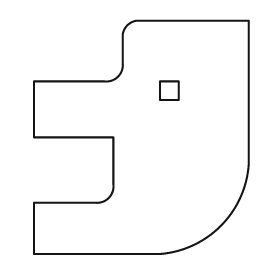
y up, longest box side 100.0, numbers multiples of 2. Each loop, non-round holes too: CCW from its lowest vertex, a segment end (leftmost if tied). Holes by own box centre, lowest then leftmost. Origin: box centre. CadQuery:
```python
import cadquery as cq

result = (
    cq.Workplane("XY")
    .moveTo(-46.0, -50.0)
    .lineTo(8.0, -50.0)
    .threePointArc((34.0, -38.0), (46.0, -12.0))
    .lineTo(46.0, 50.0)
    .lineTo(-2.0, 50.0)
    .threePointArc((-6.0, 48.0), (-8.0, 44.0))
    .lineTo(-8.0, 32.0)
    .threePointArc((-10.0, 26.0), (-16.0, 24.0))
    .lineTo(-46.0, 24.0)
    .lineTo(-46.0, 0.0)
    .lineTo(-12.0, 0.0)
    .lineTo(-12.0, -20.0)
    .threePointArc((-14.0, -26.0), (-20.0, -28.0))
    .lineTo(-46.0, -28.0)
    .close()
    .moveTo(8.0, 16.0)
    .lineTo(16.0, 16.0)
    .lineTo(16.0, 24.0)
    .lineTo(8.0, 24.0)
    .close()
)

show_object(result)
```